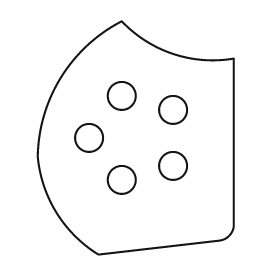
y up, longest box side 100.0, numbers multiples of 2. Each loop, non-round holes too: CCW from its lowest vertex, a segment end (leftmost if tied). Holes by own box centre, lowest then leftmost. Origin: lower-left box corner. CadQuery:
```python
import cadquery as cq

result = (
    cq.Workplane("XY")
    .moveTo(26.0, 0.0)
    .lineTo(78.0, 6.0)
    .threePointArc((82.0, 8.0), (84.0, 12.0))
    .lineTo(84.0, 84.0)
    .threePointArc((58.0, 86.0), (36.0, 100.0))
    .threePointArc((10.0, 76.0), (0.0, 42.0))
    .threePointArc((8.0, 18.0), (26.0, 0.0))
    .close()
    .moveTo(36.0, 32.0)
    .circle(6.0)
    .moveTo(58.0, 38.0)
    .circle(6.0)
    .moveTo(22.0, 50.0)
    .circle(6.0)
    .moveTo(58.0, 62.0)
    .circle(6.0)
    .moveTo(36.0, 68.0)
    .circle(6.0)
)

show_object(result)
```